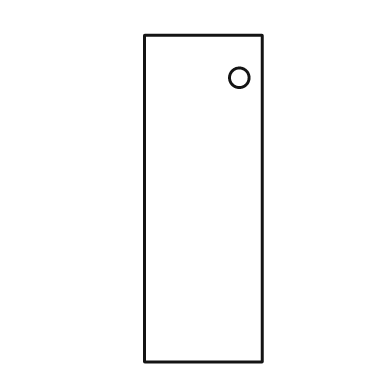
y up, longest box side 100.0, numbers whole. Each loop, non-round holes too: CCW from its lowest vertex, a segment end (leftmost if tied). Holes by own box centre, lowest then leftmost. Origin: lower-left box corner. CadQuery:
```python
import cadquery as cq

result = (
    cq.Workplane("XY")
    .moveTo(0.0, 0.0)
    .lineTo(36.0, 0.0)
    .lineTo(36.0, 100.0)
    .lineTo(0.0, 100.0)
    .close()
    .moveTo(29.0, 87.0)
    .circle(3.0)
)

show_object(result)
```